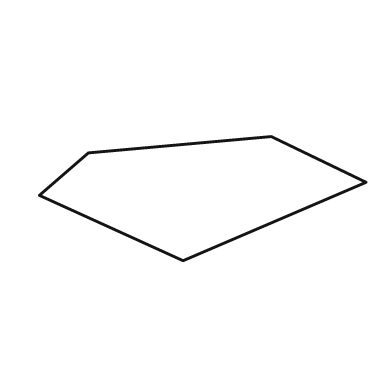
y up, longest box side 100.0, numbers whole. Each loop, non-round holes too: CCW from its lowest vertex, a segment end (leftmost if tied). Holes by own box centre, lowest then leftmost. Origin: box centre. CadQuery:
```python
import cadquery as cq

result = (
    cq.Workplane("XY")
    .moveTo(-6.0, -19.0)
    .lineTo(50.0, 5.0)
    .lineTo(21.0, 19.0)
    .lineTo(-35.0, 14.0)
    .lineTo(-50.0, 1.0)
    .close()
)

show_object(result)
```